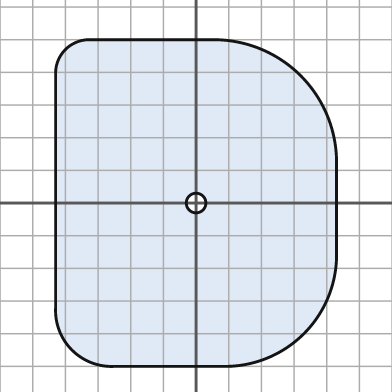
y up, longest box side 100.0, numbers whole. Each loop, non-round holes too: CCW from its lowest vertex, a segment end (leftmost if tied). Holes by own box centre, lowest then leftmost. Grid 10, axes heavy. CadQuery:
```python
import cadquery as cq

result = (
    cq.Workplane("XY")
    .moveTo(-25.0, -50.0)
    .lineTo(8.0, -50.0)
    .threePointArc((33.0, -40.0), (43.0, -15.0))
    .lineTo(43.0, 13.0)
    .threePointArc((32.0, 39.0), (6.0, 50.0))
    .lineTo(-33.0, 50.0)
    .threePointArc((-40.0, 47.0), (-43.0, 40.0))
    .lineTo(-43.0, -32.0)
    .threePointArc((-38.0, -45.0), (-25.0, -50.0))
    .close()
    .moveTo(0.0, 0.0)
    .circle(3.0)
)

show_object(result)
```